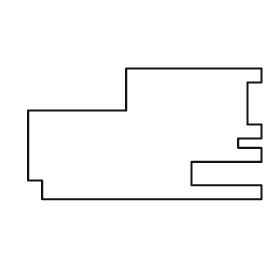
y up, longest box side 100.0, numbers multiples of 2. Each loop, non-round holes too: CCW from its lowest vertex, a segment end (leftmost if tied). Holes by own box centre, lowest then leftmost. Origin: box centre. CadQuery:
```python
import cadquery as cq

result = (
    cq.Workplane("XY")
    .moveTo(-44.0, -28.0)
    .lineTo(50.0, -28.0)
    .lineTo(50.0, -22.0)
    .lineTo(20.0, -22.0)
    .lineTo(20.0, -12.0)
    .lineTo(50.0, -12.0)
    .lineTo(50.0, -6.0)
    .lineTo(40.0, -6.0)
    .lineTo(40.0, -2.0)
    .lineTo(50.0, -2.0)
    .lineTo(50.0, 4.0)
    .lineTo(44.0, 4.0)
    .lineTo(44.0, 22.0)
    .lineTo(50.0, 22.0)
    .lineTo(50.0, 28.0)
    .lineTo(-8.0, 28.0)
    .lineTo(-8.0, 10.0)
    .lineTo(-50.0, 10.0)
    .lineTo(-50.0, -20.0)
    .lineTo(-44.0, -20.0)
    .close()
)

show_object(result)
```